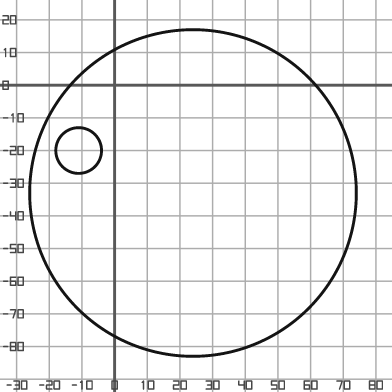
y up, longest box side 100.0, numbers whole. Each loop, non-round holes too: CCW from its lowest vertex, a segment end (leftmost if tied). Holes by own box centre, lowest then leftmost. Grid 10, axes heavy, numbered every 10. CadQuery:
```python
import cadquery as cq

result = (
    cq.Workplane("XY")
    .moveTo(24.0, -33.0)
    .circle(50.0)
    .moveTo(-11.0, -20.0)
    .circle(7.0)
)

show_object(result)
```